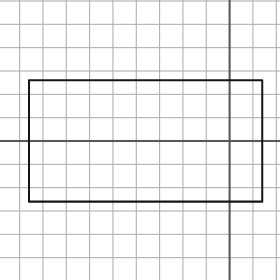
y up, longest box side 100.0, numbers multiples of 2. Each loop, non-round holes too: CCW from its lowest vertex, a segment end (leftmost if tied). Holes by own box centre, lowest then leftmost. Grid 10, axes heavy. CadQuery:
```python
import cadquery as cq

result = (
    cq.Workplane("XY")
    .moveTo(-86.0, -26.0)
    .lineTo(14.0, -26.0)
    .lineTo(14.0, 26.0)
    .lineTo(-86.0, 26.0)
    .close()
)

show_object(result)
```